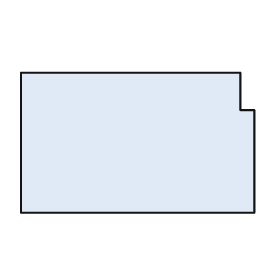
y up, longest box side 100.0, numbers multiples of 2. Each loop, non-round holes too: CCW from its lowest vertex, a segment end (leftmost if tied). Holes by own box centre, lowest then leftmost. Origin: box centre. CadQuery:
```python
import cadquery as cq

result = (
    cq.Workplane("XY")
    .moveTo(-50.0, -30.0)
    .lineTo(50.0, -30.0)
    .lineTo(50.0, 14.0)
    .lineTo(44.0, 14.0)
    .lineTo(44.0, 30.0)
    .lineTo(-50.0, 30.0)
    .close()
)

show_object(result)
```